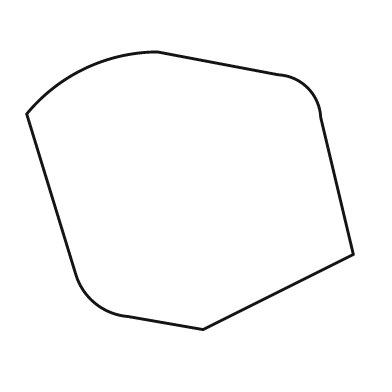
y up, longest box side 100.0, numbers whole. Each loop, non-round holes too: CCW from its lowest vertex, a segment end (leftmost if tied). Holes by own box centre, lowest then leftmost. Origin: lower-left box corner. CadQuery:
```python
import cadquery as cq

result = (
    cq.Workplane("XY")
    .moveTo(54.0, 0.0)
    .lineTo(100.0, 23.0)
    .lineTo(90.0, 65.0)
    .threePointArc((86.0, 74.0), (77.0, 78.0))
    .lineTo(40.0, 85.0)
    .threePointArc((18.0, 80.0), (0.0, 66.0))
    .lineTo(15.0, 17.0)
    .threePointArc((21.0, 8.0), (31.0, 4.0))
    .close()
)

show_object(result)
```